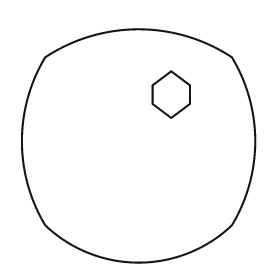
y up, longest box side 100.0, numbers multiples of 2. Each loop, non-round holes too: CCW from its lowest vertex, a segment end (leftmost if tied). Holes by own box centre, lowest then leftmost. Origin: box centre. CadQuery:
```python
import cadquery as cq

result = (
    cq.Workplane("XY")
    .moveTo(-40.0, -34.0)
    .threePointArc((0.0, -50.0), (40.0, -34.0))
    .threePointArc((50.0, 2.0), (40.0, 38.0))
    .threePointArc((0.0, 50.0), (-40.0, 38.0))
    .threePointArc((-50.0, 2.0), (-40.0, -34.0))
    .close()
    .moveTo(14.0, 12.0)
    .lineTo(22.0, 18.0)
    .lineTo(22.0, 26.0)
    .lineTo(14.0, 32.0)
    .lineTo(6.0, 26.0)
    .lineTo(6.0, 18.0)
    .close()
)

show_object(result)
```